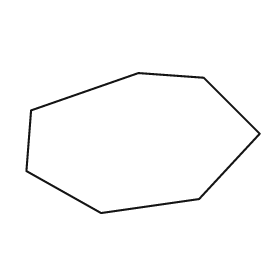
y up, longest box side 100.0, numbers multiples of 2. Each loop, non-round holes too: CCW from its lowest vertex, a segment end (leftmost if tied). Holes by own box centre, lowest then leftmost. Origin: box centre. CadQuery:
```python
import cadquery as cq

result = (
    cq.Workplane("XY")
    .moveTo(-18.0, -30.0)
    .lineTo(24.0, -24.0)
    .lineTo(50.0, 4.0)
    .lineTo(26.0, 28.0)
    .lineTo(-2.0, 30.0)
    .lineTo(-48.0, 14.0)
    .lineTo(-50.0, -12.0)
    .close()
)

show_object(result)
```